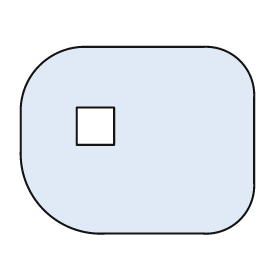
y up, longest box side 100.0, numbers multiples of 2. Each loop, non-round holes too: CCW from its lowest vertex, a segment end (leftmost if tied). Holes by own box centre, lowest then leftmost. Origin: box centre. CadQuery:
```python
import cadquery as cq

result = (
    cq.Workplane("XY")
    .moveTo(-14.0, -40.0)
    .lineTo(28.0, -40.0)
    .threePointArc((44.0, -34.0), (50.0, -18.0))
    .lineTo(50.0, 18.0)
    .threePointArc((44.0, 34.0), (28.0, 40.0))
    .lineTo(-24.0, 40.0)
    .threePointArc((-42.0, 32.0), (-50.0, 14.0))
    .lineTo(-50.0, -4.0)
    .threePointArc((-40.0, -30.0), (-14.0, -40.0))
    .close()
    .moveTo(-26.0, -2.0)
    .lineTo(-10.0, -2.0)
    .lineTo(-10.0, 14.0)
    .lineTo(-26.0, 14.0)
    .close()
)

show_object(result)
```